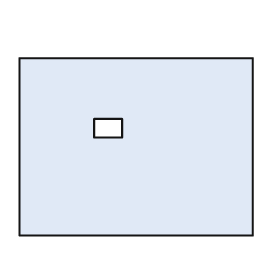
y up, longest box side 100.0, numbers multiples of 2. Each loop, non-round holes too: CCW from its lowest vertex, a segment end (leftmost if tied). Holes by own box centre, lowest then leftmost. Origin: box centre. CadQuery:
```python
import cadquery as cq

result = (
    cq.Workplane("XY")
    .moveTo(-50.0, -38.0)
    .lineTo(50.0, -38.0)
    .lineTo(50.0, 38.0)
    .lineTo(-50.0, 38.0)
    .close()
    .moveTo(-18.0, 4.0)
    .lineTo(-6.0, 4.0)
    .lineTo(-6.0, 12.0)
    .lineTo(-18.0, 12.0)
    .close()
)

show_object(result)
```